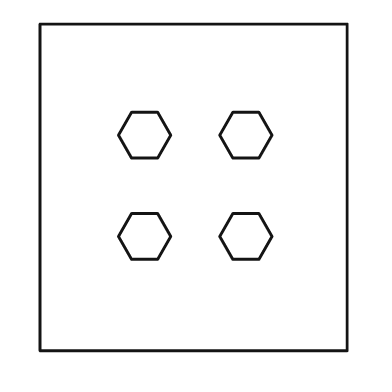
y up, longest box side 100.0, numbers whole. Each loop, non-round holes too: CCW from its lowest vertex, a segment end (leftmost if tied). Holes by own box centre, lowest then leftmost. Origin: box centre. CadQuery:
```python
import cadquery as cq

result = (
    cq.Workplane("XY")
    .moveTo(-47.0, -50.0)
    .lineTo(47.0, -50.0)
    .lineTo(47.0, 50.0)
    .lineTo(-47.0, 50.0)
    .close()
    .moveTo(-19.0, -22.0)
    .lineTo(-11.0, -22.0)
    .lineTo(-7.0, -15.0)
    .lineTo(-11.0, -8.0)
    .lineTo(-19.0, -8.0)
    .lineTo(-23.0, -15.0)
    .close()
    .moveTo(12.0, -22.0)
    .lineTo(20.0, -22.0)
    .lineTo(24.0, -15.0)
    .lineTo(20.0, -8.0)
    .lineTo(12.0, -8.0)
    .lineTo(8.0, -15.0)
    .close()
    .moveTo(-19.0, 9.0)
    .lineTo(-11.0, 9.0)
    .lineTo(-7.0, 16.0)
    .lineTo(-11.0, 23.0)
    .lineTo(-19.0, 23.0)
    .lineTo(-23.0, 16.0)
    .close()
    .moveTo(12.0, 9.0)
    .lineTo(20.0, 9.0)
    .lineTo(24.0, 16.0)
    .lineTo(20.0, 23.0)
    .lineTo(12.0, 23.0)
    .lineTo(8.0, 16.0)
    .close()
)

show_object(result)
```